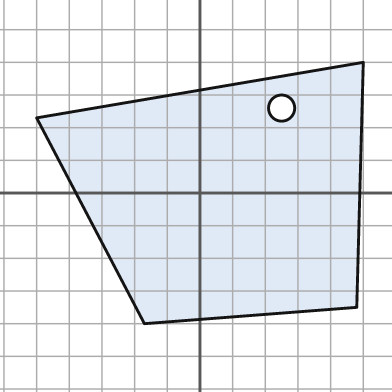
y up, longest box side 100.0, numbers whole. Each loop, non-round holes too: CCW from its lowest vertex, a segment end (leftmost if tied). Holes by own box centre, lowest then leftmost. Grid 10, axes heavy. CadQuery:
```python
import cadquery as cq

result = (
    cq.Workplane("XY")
    .moveTo(-17.0, -40.0)
    .lineTo(48.0, -35.0)
    .lineTo(50.0, 40.0)
    .lineTo(-50.0, 23.0)
    .close()
    .moveTo(25.0, 26.0)
    .circle(4.0)
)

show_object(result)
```